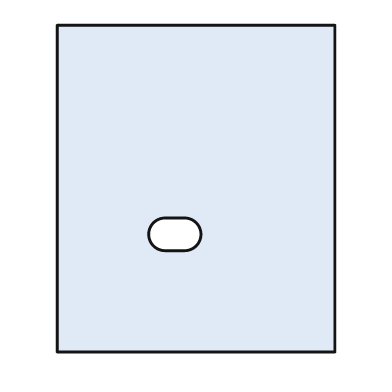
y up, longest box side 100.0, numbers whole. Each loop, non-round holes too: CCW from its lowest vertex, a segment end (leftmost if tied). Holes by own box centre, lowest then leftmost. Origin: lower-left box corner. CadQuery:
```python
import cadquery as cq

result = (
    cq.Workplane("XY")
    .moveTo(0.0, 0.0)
    .lineTo(85.0, 0.0)
    .lineTo(85.0, 100.0)
    .lineTo(0.0, 100.0)
    .close()
    .moveTo(33.0, 31.0)
    .lineTo(39.0, 31.0)
    .threePointArc((44.0, 36.0), (39.0, 41.0))
    .lineTo(33.0, 41.0)
    .threePointArc((28.0, 36.0), (33.0, 31.0))
    .close()
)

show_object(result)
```